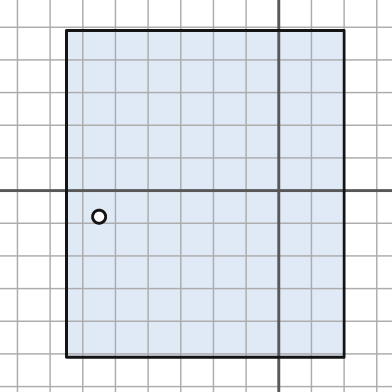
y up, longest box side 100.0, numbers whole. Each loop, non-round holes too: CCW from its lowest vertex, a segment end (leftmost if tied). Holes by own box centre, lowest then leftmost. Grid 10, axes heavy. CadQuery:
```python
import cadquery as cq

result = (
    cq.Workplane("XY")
    .moveTo(-65.0, -51.0)
    .lineTo(20.0, -51.0)
    .lineTo(20.0, 49.0)
    .lineTo(-65.0, 49.0)
    .close()
    .moveTo(-55.0, -8.0)
    .circle(2.0)
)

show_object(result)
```